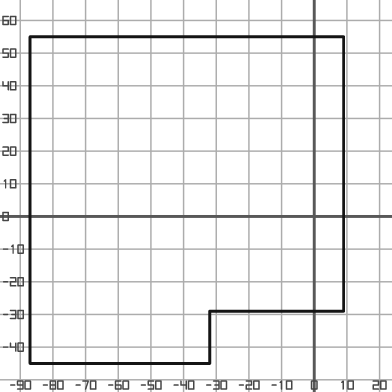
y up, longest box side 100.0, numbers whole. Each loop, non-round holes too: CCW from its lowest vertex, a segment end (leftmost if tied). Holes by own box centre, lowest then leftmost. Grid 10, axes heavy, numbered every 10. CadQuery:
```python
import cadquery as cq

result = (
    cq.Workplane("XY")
    .moveTo(-87.0, -45.0)
    .lineTo(-32.0, -45.0)
    .lineTo(-32.0, -29.0)
    .lineTo(9.0, -29.0)
    .lineTo(9.0, 55.0)
    .lineTo(-87.0, 55.0)
    .close()
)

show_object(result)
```